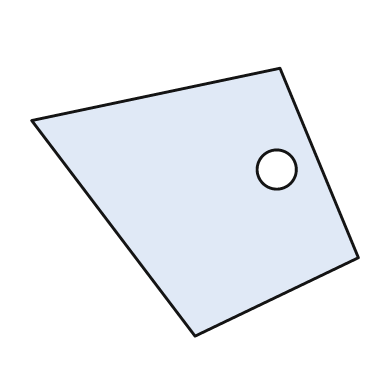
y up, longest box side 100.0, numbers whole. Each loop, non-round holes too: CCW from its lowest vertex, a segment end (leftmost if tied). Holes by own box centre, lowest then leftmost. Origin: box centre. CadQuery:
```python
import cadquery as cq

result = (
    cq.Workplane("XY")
    .moveTo(0.0, -41.0)
    .lineTo(50.0, -17.0)
    .lineTo(26.0, 41.0)
    .lineTo(-50.0, 25.0)
    .close()
    .moveTo(25.0, 10.0)
    .circle(6.0)
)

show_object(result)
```